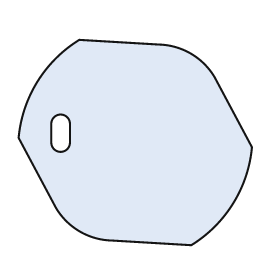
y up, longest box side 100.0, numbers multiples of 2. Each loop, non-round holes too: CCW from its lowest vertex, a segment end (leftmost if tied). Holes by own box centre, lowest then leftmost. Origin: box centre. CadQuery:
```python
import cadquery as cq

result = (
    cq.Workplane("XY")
    .moveTo(24.0, -44.0)
    .threePointArc((42.0, -26.0), (50.0, -2.0))
    .lineTo(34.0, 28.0)
    .threePointArc((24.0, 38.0), (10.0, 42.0))
    .lineTo(-24.0, 44.0)
    .threePointArc((-42.0, 26.0), (-50.0, 2.0))
    .lineTo(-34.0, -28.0)
    .threePointArc((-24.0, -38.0), (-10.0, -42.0))
    .close()
    .moveTo(-36.0, 0.0)
    .threePointArc((-32.0, -4.0), (-28.0, 0.0))
    .lineTo(-28.0, 8.0)
    .threePointArc((-32.0, 12.0), (-36.0, 8.0))
    .close()
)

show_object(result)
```